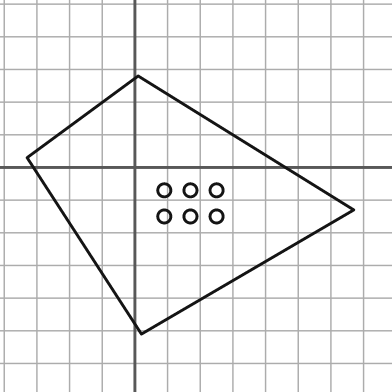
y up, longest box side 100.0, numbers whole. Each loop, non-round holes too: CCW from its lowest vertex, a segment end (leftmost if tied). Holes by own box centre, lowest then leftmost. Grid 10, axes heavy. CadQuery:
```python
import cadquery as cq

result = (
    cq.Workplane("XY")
    .moveTo(2.0, -51.0)
    .lineTo(67.0, -13.0)
    .lineTo(1.0, 28.0)
    .lineTo(-33.0, 3.0)
    .close()
    .moveTo(9.0, -15.0)
    .circle(2.0)
    .moveTo(17.0, -15.0)
    .circle(2.0)
    .moveTo(25.0, -15.0)
    .circle(2.0)
    .moveTo(9.0, -7.0)
    .circle(2.0)
    .moveTo(17.0, -7.0)
    .circle(2.0)
    .moveTo(25.0, -7.0)
    .circle(2.0)
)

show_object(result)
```